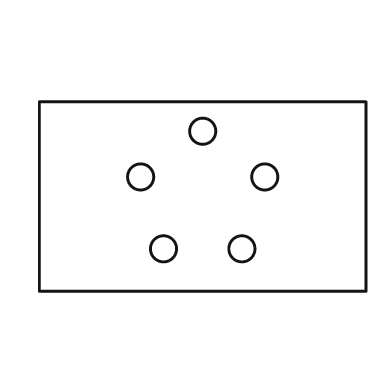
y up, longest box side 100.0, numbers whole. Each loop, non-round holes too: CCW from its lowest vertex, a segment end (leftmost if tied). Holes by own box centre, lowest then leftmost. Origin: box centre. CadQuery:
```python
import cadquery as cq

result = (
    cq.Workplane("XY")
    .moveTo(-50.0, -29.0)
    .lineTo(50.0, -29.0)
    .lineTo(50.0, 29.0)
    .lineTo(-50.0, 29.0)
    .close()
    .moveTo(-12.0, -16.0)
    .circle(4.0)
    .moveTo(12.0, -16.0)
    .circle(4.0)
    .moveTo(-19.0, 6.0)
    .circle(4.0)
    .moveTo(19.0, 6.0)
    .circle(4.0)
    .moveTo(0.0, 20.0)
    .circle(4.0)
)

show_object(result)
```